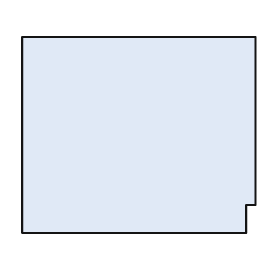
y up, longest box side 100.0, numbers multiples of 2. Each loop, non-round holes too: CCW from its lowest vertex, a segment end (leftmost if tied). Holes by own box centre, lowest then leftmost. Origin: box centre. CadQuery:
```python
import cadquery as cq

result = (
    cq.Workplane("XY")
    .moveTo(-50.0, -42.0)
    .lineTo(46.0, -42.0)
    .lineTo(46.0, -30.0)
    .lineTo(50.0, -30.0)
    .lineTo(50.0, 42.0)
    .lineTo(-50.0, 42.0)
    .close()
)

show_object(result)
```